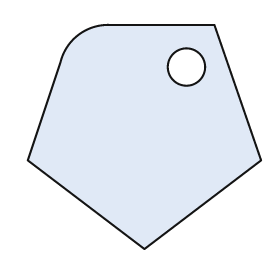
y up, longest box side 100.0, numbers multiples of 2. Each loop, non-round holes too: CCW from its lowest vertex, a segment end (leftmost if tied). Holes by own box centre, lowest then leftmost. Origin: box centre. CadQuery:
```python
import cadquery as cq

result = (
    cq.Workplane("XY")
    .moveTo(0.0, -48.0)
    .lineTo(50.0, -10.0)
    .lineTo(30.0, 48.0)
    .lineTo(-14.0, 48.0)
    .threePointArc((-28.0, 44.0), (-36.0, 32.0))
    .lineTo(-50.0, -10.0)
    .close()
    .moveTo(18.0, 30.0)
    .circle(8.0)
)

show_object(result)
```